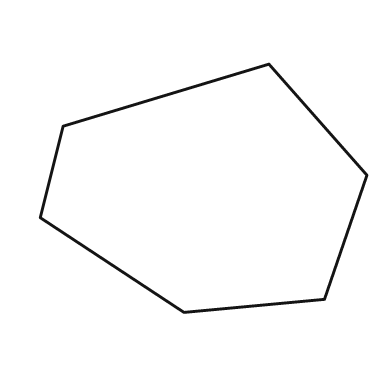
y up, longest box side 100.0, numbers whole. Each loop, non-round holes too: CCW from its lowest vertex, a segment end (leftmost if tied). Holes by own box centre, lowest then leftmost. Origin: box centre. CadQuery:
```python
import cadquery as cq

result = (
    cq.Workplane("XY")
    .moveTo(-6.0, -38.0)
    .lineTo(37.0, -34.0)
    .lineTo(50.0, 4.0)
    .lineTo(20.0, 38.0)
    .lineTo(-43.0, 19.0)
    .lineTo(-50.0, -9.0)
    .close()
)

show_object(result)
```